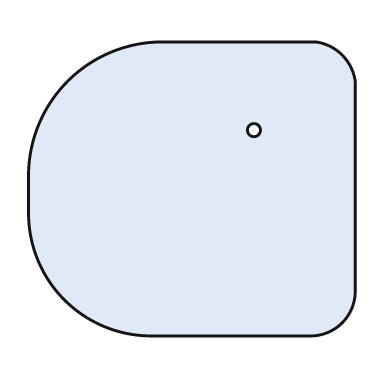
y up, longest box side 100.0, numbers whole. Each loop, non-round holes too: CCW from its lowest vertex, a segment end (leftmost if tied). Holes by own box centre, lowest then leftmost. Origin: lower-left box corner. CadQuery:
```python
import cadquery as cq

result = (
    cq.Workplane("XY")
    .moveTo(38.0, 0.0)
    .lineTo(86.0, 0.0)
    .threePointArc((96.0, 4.0), (100.0, 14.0))
    .lineTo(100.0, 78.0)
    .threePointArc((96.0, 86.0), (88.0, 90.0))
    .lineTo(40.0, 90.0)
    .threePointArc((12.0, 78.0), (0.0, 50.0))
    .lineTo(0.0, 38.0)
    .threePointArc((11.0, 11.0), (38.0, 0.0))
    .close()
    .moveTo(69.0, 63.0)
    .circle(2.0)
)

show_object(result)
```